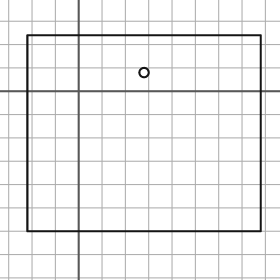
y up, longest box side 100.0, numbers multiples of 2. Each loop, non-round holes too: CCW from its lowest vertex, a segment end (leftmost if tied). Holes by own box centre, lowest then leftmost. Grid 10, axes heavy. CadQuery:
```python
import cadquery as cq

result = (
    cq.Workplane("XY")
    .moveTo(-22.0, -60.0)
    .lineTo(78.0, -60.0)
    .lineTo(78.0, 24.0)
    .lineTo(-22.0, 24.0)
    .close()
    .moveTo(28.0, 8.0)
    .circle(2.0)
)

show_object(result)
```